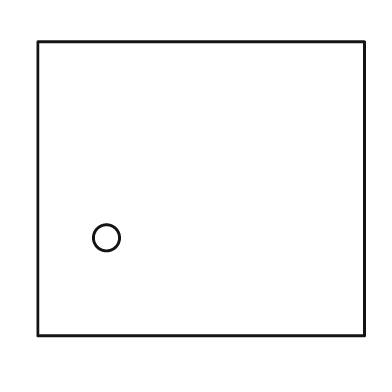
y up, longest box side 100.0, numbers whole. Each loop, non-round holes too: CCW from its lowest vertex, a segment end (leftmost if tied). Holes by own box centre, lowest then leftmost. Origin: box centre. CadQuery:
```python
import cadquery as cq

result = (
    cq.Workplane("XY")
    .moveTo(-50.0, -45.0)
    .lineTo(50.0, -45.0)
    .lineTo(50.0, 45.0)
    .lineTo(-50.0, 45.0)
    .close()
    .moveTo(-29.0, -15.0)
    .circle(4.0)
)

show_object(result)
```